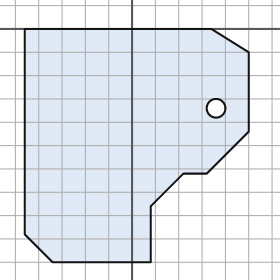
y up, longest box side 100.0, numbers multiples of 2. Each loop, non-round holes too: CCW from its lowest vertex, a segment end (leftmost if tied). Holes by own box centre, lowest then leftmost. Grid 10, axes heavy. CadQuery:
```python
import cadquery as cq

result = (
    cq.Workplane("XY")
    .moveTo(-34.0, -100.0)
    .lineTo(8.0, -100.0)
    .lineTo(8.0, -76.0)
    .lineTo(22.0, -62.0)
    .lineTo(32.0, -62.0)
    .lineTo(50.0, -44.0)
    .lineTo(50.0, -10.0)
    .lineTo(34.0, 0.0)
    .lineTo(-46.0, 0.0)
    .lineTo(-46.0, -88.0)
    .close()
    .moveTo(36.0, -34.0)
    .circle(4.0)
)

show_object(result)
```